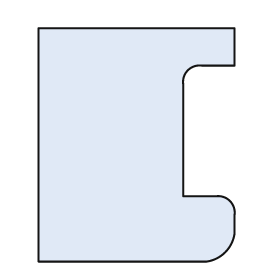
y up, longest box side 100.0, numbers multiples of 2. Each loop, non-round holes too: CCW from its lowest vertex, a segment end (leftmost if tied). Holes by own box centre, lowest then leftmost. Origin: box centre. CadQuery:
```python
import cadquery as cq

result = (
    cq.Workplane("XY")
    .moveTo(-42.0, -50.0)
    .lineTo(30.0, -50.0)
    .threePointArc((38.0, -46.0), (42.0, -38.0))
    .lineTo(42.0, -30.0)
    .threePointArc((40.0, -24.0), (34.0, -22.0))
    .lineTo(20.0, -22.0)
    .lineTo(20.0, 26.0)
    .threePointArc((22.0, 32.0), (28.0, 34.0))
    .lineTo(42.0, 34.0)
    .lineTo(42.0, 50.0)
    .lineTo(-42.0, 50.0)
    .close()
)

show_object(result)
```